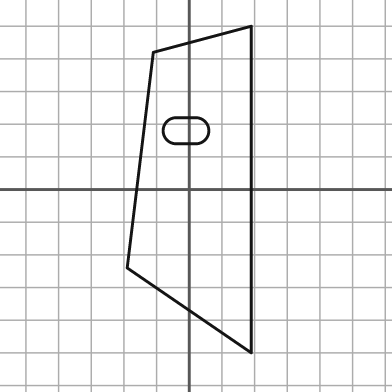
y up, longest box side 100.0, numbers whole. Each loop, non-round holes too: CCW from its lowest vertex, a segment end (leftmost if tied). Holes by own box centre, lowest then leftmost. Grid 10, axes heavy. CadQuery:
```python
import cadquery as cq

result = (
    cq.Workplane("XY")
    .moveTo(19.0, -50.0)
    .lineTo(19.0, 50.0)
    .lineTo(-11.0, 42.0)
    .lineTo(-19.0, -24.0)
    .close()
    .moveTo(-4.0, 14.0)
    .lineTo(2.0, 14.0)
    .threePointArc((6.0, 18.0), (2.0, 22.0))
    .lineTo(-4.0, 22.0)
    .threePointArc((-8.0, 18.0), (-4.0, 14.0))
    .close()
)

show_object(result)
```